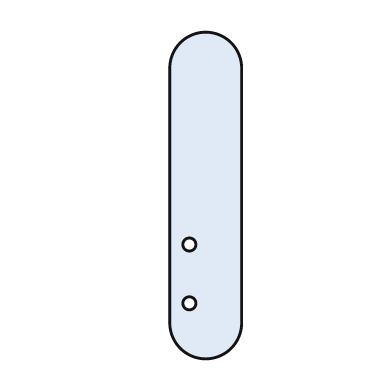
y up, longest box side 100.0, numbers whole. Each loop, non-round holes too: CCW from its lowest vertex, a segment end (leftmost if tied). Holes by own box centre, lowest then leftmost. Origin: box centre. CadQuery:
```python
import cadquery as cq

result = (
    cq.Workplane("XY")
    .moveTo(-11.0, -39.0)
    .threePointArc((0.0, -50.0), (11.0, -39.0))
    .lineTo(11.0, 39.0)
    .threePointArc((0.0, 50.0), (-11.0, 39.0))
    .close()
    .moveTo(-5.0, -33.0)
    .circle(2.0)
    .moveTo(-5.0, -15.0)
    .circle(2.0)
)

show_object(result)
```